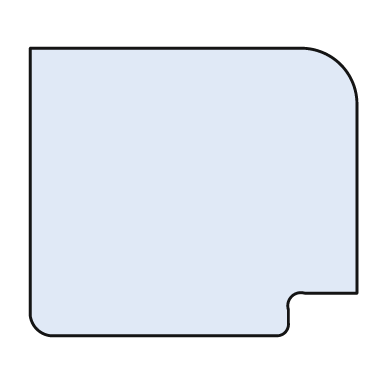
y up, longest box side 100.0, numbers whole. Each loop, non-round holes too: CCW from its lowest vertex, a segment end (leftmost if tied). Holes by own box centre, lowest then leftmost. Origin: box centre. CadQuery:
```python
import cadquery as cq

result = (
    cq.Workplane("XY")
    .moveTo(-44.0, -44.0)
    .lineTo(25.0, -44.0)
    .threePointArc((28.0, -43.0), (29.0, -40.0))
    .lineTo(29.0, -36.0)
    .threePointArc((30.0, -32.0), (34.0, -31.0))
    .lineTo(50.0, -31.0)
    .lineTo(50.0, 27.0)
    .threePointArc((45.0, 39.0), (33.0, 44.0))
    .lineTo(-50.0, 44.0)
    .lineTo(-50.0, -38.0)
    .threePointArc((-48.0, -42.0), (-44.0, -44.0))
    .close()
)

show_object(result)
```